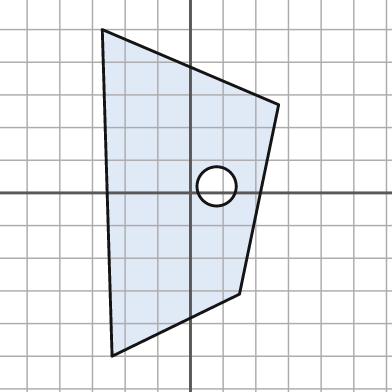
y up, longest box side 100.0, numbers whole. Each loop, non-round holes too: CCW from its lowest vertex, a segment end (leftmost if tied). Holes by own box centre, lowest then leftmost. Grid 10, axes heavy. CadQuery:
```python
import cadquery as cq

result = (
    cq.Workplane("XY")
    .moveTo(-24.0, -50.0)
    .lineTo(15.0, -31.0)
    .lineTo(27.0, 27.0)
    .lineTo(-27.0, 50.0)
    .close()
    .moveTo(8.0, 2.0)
    .circle(6.0)
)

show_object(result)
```